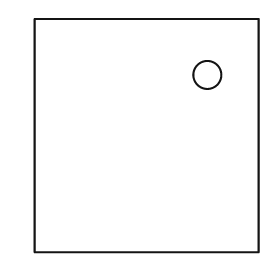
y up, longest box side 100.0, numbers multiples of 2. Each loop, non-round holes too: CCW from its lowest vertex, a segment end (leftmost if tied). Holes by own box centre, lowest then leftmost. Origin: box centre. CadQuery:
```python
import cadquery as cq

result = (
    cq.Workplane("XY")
    .moveTo(-48.0, -50.0)
    .lineTo(48.0, -50.0)
    .lineTo(48.0, 50.0)
    .lineTo(-48.0, 50.0)
    .close()
    .moveTo(26.0, 26.0)
    .circle(6.0)
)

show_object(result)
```